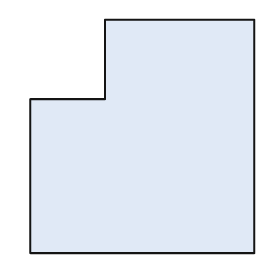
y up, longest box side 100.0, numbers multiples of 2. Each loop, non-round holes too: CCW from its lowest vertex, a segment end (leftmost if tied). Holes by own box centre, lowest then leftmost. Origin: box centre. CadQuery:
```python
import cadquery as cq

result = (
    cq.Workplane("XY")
    .moveTo(-48.0, -50.0)
    .lineTo(48.0, -50.0)
    .lineTo(48.0, 50.0)
    .lineTo(-16.0, 50.0)
    .lineTo(-16.0, 16.0)
    .lineTo(-48.0, 16.0)
    .close()
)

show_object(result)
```